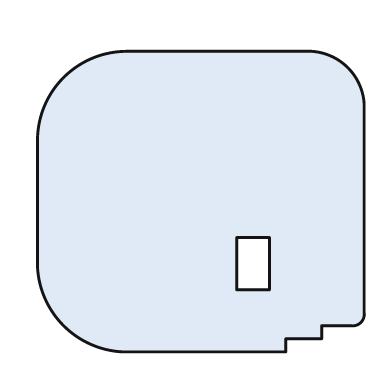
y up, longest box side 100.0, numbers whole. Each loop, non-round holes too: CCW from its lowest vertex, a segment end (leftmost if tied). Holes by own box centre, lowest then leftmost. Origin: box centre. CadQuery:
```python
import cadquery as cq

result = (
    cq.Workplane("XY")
    .moveTo(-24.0, -46.0)
    .lineTo(26.0, -46.0)
    .lineTo(26.0, -42.0)
    .lineTo(37.0, -42.0)
    .lineTo(37.0, -38.0)
    .lineTo(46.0, -38.0)
    .threePointArc((49.0, -37.0), (50.0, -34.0))
    .lineTo(50.0, 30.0)
    .threePointArc((45.0, 41.0), (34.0, 46.0))
    .lineTo(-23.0, 46.0)
    .threePointArc((-42.0, 38.0), (-50.0, 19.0))
    .lineTo(-50.0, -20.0)
    .threePointArc((-42.0, -38.0), (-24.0, -46.0))
    .close()
    .moveTo(11.0, -27.0)
    .lineTo(21.0, -27.0)
    .lineTo(21.0, -11.0)
    .lineTo(11.0, -11.0)
    .close()
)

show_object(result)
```